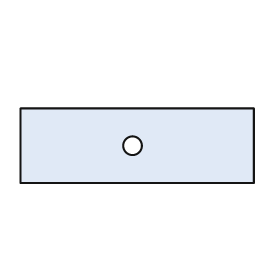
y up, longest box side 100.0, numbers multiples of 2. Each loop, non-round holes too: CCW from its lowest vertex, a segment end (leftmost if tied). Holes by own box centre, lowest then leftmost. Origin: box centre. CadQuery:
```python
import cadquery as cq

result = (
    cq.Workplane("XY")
    .moveTo(-50.0, -16.0)
    .lineTo(50.0, -16.0)
    .lineTo(50.0, 16.0)
    .lineTo(-50.0, 16.0)
    .close()
    .moveTo(-2.0, 0.0)
    .circle(4.0)
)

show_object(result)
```